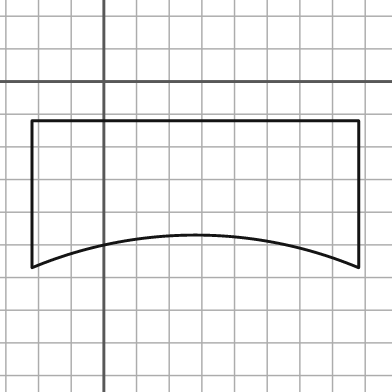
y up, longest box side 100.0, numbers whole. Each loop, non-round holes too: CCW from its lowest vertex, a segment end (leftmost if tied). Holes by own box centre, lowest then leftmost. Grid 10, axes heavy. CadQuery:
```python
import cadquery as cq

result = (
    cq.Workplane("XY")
    .moveTo(-22.0, -57.0)
    .threePointArc((28.0, -47.0), (78.0, -57.0))
    .lineTo(78.0, -12.0)
    .lineTo(-22.0, -12.0)
    .close()
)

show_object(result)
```